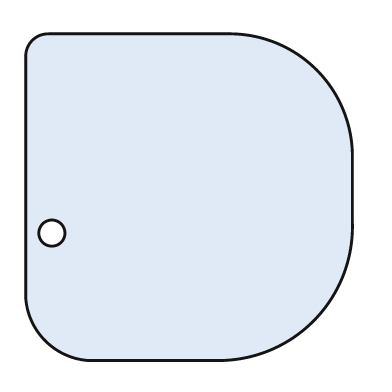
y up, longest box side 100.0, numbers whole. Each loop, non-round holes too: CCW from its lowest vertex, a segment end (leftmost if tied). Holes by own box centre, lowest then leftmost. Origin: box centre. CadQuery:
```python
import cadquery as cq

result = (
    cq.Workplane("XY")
    .moveTo(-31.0, -50.0)
    .lineTo(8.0, -50.0)
    .threePointArc((38.0, -38.0), (50.0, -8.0))
    .lineTo(50.0, 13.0)
    .threePointArc((39.0, 39.0), (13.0, 50.0))
    .lineTo(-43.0, 50.0)
    .threePointArc((-48.0, 48.0), (-50.0, 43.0))
    .lineTo(-50.0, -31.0)
    .threePointArc((-44.0, -44.0), (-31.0, -50.0))
    .close()
    .moveTo(-42.0, -11.0)
    .circle(4.0)
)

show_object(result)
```